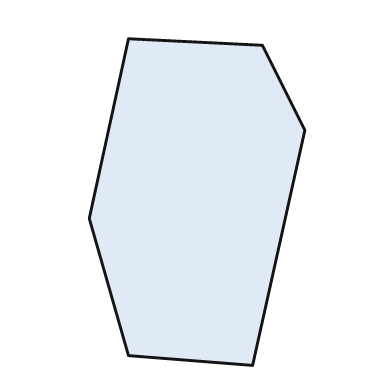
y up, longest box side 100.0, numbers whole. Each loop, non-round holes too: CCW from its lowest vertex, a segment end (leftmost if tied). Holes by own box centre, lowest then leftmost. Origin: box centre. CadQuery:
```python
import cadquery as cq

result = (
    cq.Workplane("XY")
    .moveTo(17.0, -50.0)
    .lineTo(33.0, 22.0)
    .lineTo(20.0, 48.0)
    .lineTo(-21.0, 50.0)
    .lineTo(-33.0, -5.0)
    .lineTo(-21.0, -47.0)
    .close()
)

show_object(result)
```